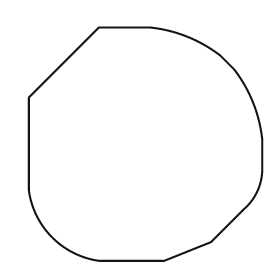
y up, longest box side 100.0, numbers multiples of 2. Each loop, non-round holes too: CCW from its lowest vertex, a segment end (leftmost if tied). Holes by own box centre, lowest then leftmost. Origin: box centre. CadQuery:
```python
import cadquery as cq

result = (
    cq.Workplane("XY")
    .moveTo(-20.0, -50.0)
    .lineTo(8.0, -50.0)
    .lineTo(28.0, -42.0)
    .lineTo(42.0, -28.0)
    .threePointArc((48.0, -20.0), (50.0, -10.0))
    .lineTo(50.0, 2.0)
    .threePointArc((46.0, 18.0), (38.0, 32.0))
    .lineTo(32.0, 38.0)
    .threePointArc((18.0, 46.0), (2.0, 50.0))
    .lineTo(-20.0, 50.0)
    .lineTo(-50.0, 20.0)
    .lineTo(-50.0, -20.0)
    .threePointArc((-40.0, -40.0), (-20.0, -50.0))
    .close()
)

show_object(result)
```